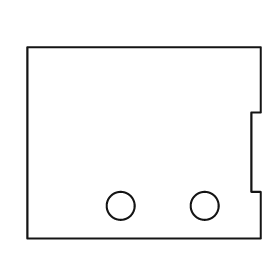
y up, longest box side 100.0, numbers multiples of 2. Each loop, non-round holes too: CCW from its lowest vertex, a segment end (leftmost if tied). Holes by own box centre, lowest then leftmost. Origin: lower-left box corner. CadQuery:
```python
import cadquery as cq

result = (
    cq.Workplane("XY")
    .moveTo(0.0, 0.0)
    .lineTo(100.0, 0.0)
    .lineTo(100.0, 20.0)
    .lineTo(96.0, 20.0)
    .lineTo(96.0, 54.0)
    .lineTo(100.0, 54.0)
    .lineTo(100.0, 82.0)
    .lineTo(0.0, 82.0)
    .close()
    .moveTo(40.0, 14.0)
    .circle(6.0)
    .moveTo(76.0, 14.0)
    .circle(6.0)
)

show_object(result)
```